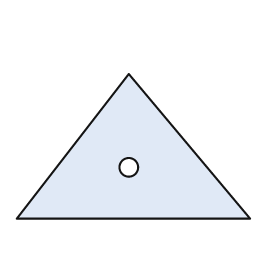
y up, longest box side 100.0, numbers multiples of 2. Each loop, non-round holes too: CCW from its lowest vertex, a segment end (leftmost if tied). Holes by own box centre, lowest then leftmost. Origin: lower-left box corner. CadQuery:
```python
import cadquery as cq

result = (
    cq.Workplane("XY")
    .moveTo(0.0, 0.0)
    .lineTo(100.0, 0.0)
    .lineTo(48.0, 62.0)
    .close()
    .moveTo(48.0, 22.0)
    .circle(4.0)
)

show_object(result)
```